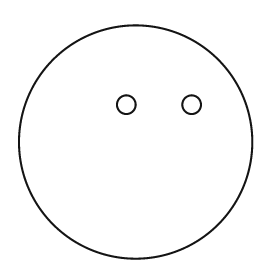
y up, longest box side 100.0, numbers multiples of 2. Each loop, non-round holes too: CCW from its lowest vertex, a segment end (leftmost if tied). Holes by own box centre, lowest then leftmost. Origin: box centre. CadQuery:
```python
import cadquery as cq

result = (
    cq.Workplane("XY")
    .moveTo(0.0, 0.0)
    .circle(50.0)
    .moveTo(-4.0, 16.0)
    .circle(4.0)
    .moveTo(24.0, 16.0)
    .circle(4.0)
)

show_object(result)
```